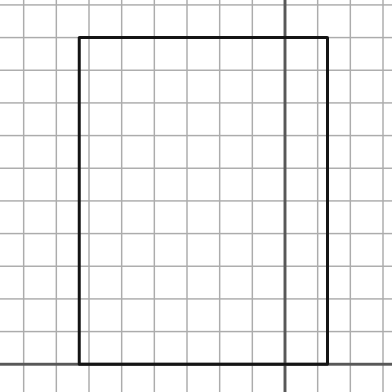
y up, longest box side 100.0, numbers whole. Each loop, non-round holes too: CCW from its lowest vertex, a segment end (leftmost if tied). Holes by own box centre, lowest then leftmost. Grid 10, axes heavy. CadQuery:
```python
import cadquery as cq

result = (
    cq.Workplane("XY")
    .moveTo(-63.0, 0.0)
    .lineTo(13.0, 0.0)
    .lineTo(13.0, 100.0)
    .lineTo(-63.0, 100.0)
    .close()
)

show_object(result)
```